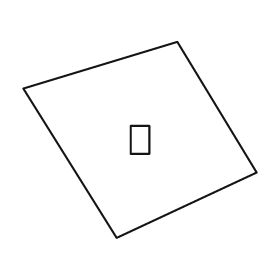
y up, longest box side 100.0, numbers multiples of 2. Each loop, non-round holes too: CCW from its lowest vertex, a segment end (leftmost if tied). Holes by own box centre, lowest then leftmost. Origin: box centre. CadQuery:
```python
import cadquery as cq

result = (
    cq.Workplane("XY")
    .moveTo(-10.0, -42.0)
    .lineTo(50.0, -14.0)
    .lineTo(16.0, 42.0)
    .lineTo(-50.0, 22.0)
    .close()
    .moveTo(-4.0, -6.0)
    .lineTo(4.0, -6.0)
    .lineTo(4.0, 6.0)
    .lineTo(-4.0, 6.0)
    .close()
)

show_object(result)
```